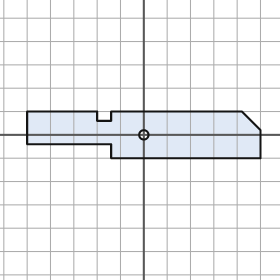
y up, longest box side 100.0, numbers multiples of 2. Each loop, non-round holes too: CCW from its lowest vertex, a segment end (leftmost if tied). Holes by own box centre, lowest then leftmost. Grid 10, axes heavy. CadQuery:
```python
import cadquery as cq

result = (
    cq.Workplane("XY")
    .moveTo(-14.0, -10.0)
    .lineTo(50.0, -10.0)
    .lineTo(50.0, 2.0)
    .lineTo(42.0, 10.0)
    .lineTo(-14.0, 10.0)
    .lineTo(-14.0, 6.0)
    .lineTo(-20.0, 6.0)
    .lineTo(-20.0, 10.0)
    .lineTo(-50.0, 10.0)
    .lineTo(-50.0, -4.0)
    .lineTo(-14.0, -4.0)
    .close()
    .moveTo(0.0, 0.0)
    .circle(2.0)
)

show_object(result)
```